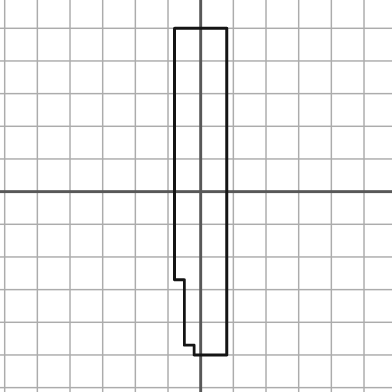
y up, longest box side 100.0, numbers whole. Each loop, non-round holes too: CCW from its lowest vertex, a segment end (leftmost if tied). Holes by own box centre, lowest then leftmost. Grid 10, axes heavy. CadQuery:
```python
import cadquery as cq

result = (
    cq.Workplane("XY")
    .moveTo(-2.0, -50.0)
    .lineTo(8.0, -50.0)
    .lineTo(8.0, 50.0)
    .lineTo(-8.0, 50.0)
    .lineTo(-8.0, -27.0)
    .lineTo(-5.0, -27.0)
    .lineTo(-5.0, -47.0)
    .lineTo(-2.0, -47.0)
    .close()
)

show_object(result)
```